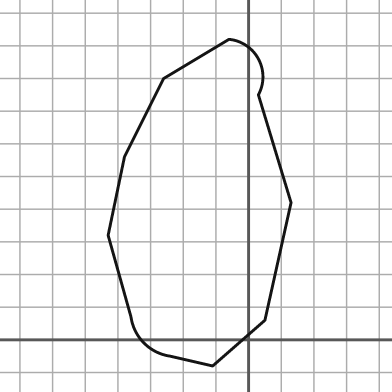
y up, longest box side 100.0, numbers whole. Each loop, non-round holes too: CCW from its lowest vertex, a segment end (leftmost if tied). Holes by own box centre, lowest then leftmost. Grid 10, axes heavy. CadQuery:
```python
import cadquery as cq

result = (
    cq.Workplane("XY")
    .moveTo(-11.0, -8.0)
    .lineTo(5.0, 6.0)
    .lineTo(13.0, 42.0)
    .lineTo(3.0, 75.0)
    .threePointArc((3.0, 86.0), (-6.0, 92.0))
    .lineTo(-26.0, 80.0)
    .lineTo(-38.0, 56.0)
    .lineTo(-43.0, 32.0)
    .lineTo(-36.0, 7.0)
    .threePointArc((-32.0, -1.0), (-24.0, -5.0))
    .close()
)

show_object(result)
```